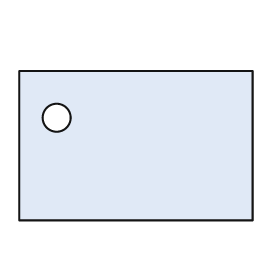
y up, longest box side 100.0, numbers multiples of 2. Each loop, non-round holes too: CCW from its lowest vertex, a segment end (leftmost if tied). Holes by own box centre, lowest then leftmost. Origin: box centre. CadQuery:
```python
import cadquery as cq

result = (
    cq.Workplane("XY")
    .moveTo(-50.0, -32.0)
    .lineTo(50.0, -32.0)
    .lineTo(50.0, 32.0)
    .lineTo(-50.0, 32.0)
    .close()
    .moveTo(-34.0, 12.0)
    .circle(6.0)
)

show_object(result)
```